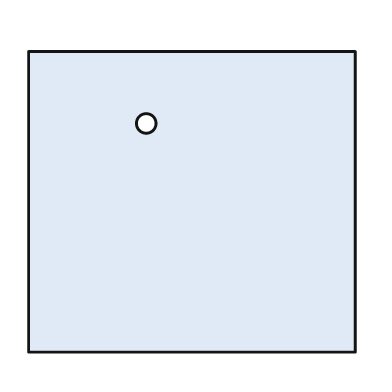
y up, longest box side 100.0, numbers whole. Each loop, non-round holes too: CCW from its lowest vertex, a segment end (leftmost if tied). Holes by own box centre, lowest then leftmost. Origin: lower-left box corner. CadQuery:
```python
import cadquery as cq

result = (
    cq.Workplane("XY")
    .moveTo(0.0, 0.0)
    .lineTo(100.0, 0.0)
    .lineTo(100.0, 92.0)
    .lineTo(0.0, 92.0)
    .close()
    .moveTo(36.0, 70.0)
    .circle(3.0)
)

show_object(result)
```